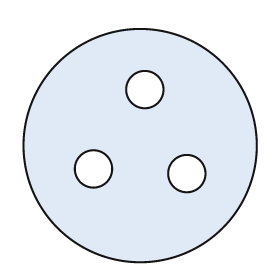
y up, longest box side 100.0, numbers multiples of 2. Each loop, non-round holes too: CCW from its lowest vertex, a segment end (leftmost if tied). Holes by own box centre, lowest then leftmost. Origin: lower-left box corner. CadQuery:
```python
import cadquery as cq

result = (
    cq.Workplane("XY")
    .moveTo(50.0, 50.0)
    .circle(50.0)
    .moveTo(70.0, 38.0)
    .circle(8.0)
    .moveTo(30.0, 40.0)
    .circle(8.0)
    .moveTo(52.0, 74.0)
    .circle(8.0)
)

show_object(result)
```